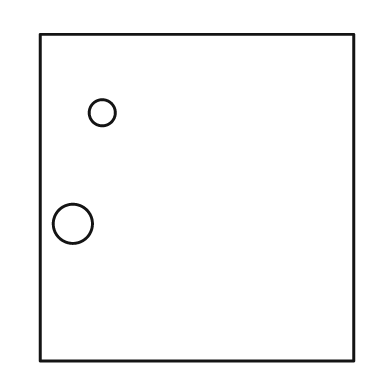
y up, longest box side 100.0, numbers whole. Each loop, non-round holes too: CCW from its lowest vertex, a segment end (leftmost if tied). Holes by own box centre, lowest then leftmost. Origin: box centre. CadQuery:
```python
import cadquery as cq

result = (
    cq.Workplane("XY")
    .moveTo(-48.0, -50.0)
    .lineTo(48.0, -50.0)
    .lineTo(48.0, 50.0)
    .lineTo(-48.0, 50.0)
    .close()
    .moveTo(-38.0, -8.0)
    .circle(6.0)
    .moveTo(-29.0, 26.0)
    .circle(4.0)
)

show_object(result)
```